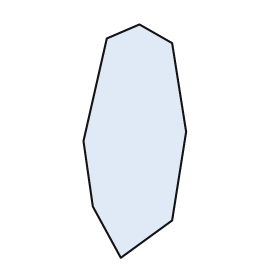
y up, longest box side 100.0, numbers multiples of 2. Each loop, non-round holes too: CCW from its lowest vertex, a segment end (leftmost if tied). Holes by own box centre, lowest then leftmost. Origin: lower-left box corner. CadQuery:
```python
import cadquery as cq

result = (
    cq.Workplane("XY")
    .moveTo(16.0, 0.0)
    .lineTo(38.0, 16.0)
    .lineTo(44.0, 54.0)
    .lineTo(38.0, 92.0)
    .lineTo(24.0, 100.0)
    .lineTo(10.0, 94.0)
    .lineTo(0.0, 50.0)
    .lineTo(4.0, 22.0)
    .close()
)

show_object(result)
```